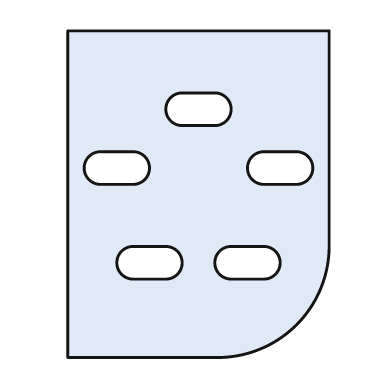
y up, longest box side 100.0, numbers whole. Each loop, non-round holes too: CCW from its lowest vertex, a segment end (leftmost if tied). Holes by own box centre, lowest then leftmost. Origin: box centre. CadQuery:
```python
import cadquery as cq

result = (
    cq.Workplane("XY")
    .moveTo(-40.0, -50.0)
    .lineTo(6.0, -50.0)
    .threePointArc((30.0, -40.0), (40.0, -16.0))
    .lineTo(40.0, 50.0)
    .lineTo(-40.0, 50.0)
    .close()
    .moveTo(-20.0, -26.0)
    .lineTo(-10.0, -26.0)
    .threePointArc((-5.0, -21.0), (-10.0, -16.0))
    .lineTo(-20.0, -16.0)
    .threePointArc((-25.0, -21.0), (-20.0, -26.0))
    .close()
    .moveTo(10.0, -26.0)
    .lineTo(20.0, -26.0)
    .threePointArc((25.0, -21.0), (20.0, -16.0))
    .lineTo(10.0, -16.0)
    .threePointArc((5.0, -21.0), (10.0, -26.0))
    .close()
    .moveTo(-30.0, 3.0)
    .lineTo(-20.0, 3.0)
    .threePointArc((-15.0, 8.0), (-20.0, 13.0))
    .lineTo(-30.0, 13.0)
    .threePointArc((-35.0, 8.0), (-30.0, 3.0))
    .close()
    .moveTo(20.0, 3.0)
    .lineTo(30.0, 3.0)
    .threePointArc((35.0, 8.0), (30.0, 13.0))
    .lineTo(20.0, 13.0)
    .threePointArc((15.0, 8.0), (20.0, 3.0))
    .close()
    .moveTo(-5.0, 21.0)
    .lineTo(5.0, 21.0)
    .threePointArc((10.0, 26.0), (5.0, 31.0))
    .lineTo(-5.0, 31.0)
    .threePointArc((-10.0, 26.0), (-5.0, 21.0))
    .close()
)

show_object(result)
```